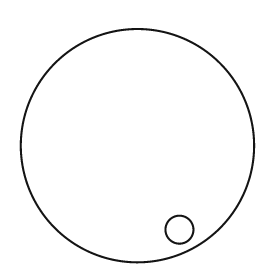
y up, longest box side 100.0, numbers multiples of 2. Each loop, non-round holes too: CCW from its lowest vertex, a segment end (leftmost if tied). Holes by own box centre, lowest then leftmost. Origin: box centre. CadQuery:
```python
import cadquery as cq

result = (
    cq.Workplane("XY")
    .moveTo(0.0, 0.0)
    .circle(50.0)
    .moveTo(18.0, -36.0)
    .circle(6.0)
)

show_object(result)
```